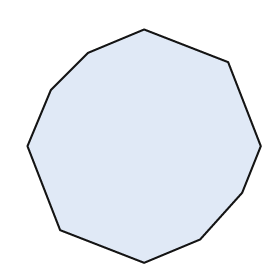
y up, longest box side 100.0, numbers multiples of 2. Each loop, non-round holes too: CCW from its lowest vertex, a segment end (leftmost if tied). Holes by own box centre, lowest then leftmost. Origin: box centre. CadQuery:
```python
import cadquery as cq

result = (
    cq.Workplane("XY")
    .moveTo(0.0, -50.0)
    .lineTo(24.0, -40.0)
    .lineTo(42.0, -20.0)
    .lineTo(50.0, 0.0)
    .lineTo(36.0, 36.0)
    .lineTo(0.0, 50.0)
    .lineTo(-24.0, 40.0)
    .lineTo(-40.0, 24.0)
    .lineTo(-50.0, 0.0)
    .lineTo(-36.0, -36.0)
    .close()
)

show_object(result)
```